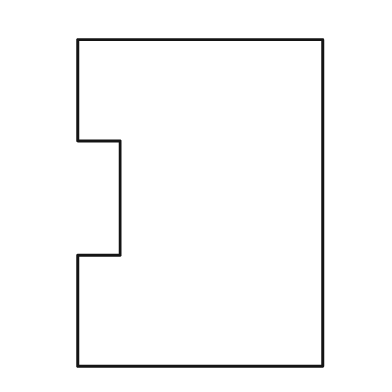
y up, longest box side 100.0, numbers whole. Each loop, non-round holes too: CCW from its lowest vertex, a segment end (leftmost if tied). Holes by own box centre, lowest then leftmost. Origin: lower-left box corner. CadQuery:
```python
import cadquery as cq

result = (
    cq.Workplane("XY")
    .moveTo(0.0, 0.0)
    .lineTo(75.0, 0.0)
    .lineTo(75.0, 100.0)
    .lineTo(0.0, 100.0)
    .lineTo(0.0, 69.0)
    .lineTo(13.0, 69.0)
    .lineTo(13.0, 34.0)
    .lineTo(0.0, 34.0)
    .close()
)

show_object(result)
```